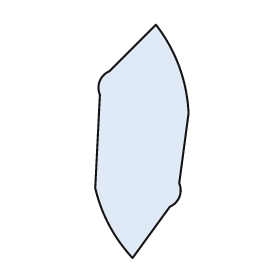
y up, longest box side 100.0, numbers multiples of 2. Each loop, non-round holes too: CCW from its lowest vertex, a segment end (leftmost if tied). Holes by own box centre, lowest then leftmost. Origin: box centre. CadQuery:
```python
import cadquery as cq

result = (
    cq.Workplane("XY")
    .moveTo(-4.0, -50.0)
    .lineTo(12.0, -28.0)
    .threePointArc((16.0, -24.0), (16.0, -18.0))
    .lineTo(20.0, 12.0)
    .threePointArc((16.0, 32.0), (6.0, 50.0))
    .lineTo(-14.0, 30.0)
    .threePointArc((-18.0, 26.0), (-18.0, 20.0))
    .lineTo(-20.0, -20.0)
    .threePointArc((-14.0, -36.0), (-4.0, -50.0))
    .close()
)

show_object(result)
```